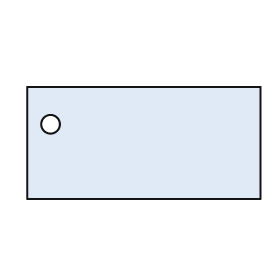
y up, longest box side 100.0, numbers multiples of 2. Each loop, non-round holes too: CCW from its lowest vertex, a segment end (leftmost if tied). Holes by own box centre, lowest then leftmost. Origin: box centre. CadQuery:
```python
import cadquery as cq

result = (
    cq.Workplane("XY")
    .moveTo(-50.0, -24.0)
    .lineTo(50.0, -24.0)
    .lineTo(50.0, 24.0)
    .lineTo(-50.0, 24.0)
    .close()
    .moveTo(-40.0, 8.0)
    .circle(4.0)
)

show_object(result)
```